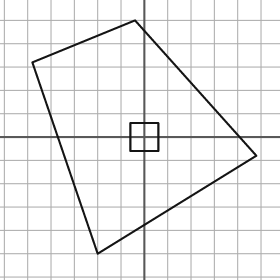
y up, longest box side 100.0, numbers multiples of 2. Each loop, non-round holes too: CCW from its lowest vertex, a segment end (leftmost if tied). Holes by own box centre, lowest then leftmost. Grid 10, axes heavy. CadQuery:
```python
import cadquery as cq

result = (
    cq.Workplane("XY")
    .moveTo(-20.0, -50.0)
    .lineTo(48.0, -8.0)
    .lineTo(-4.0, 50.0)
    .lineTo(-48.0, 32.0)
    .close()
    .moveTo(-6.0, -6.0)
    .lineTo(6.0, -6.0)
    .lineTo(6.0, 6.0)
    .lineTo(-6.0, 6.0)
    .close()
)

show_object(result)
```